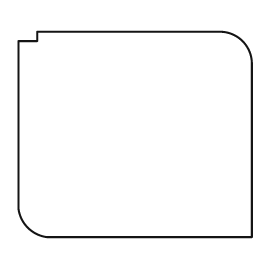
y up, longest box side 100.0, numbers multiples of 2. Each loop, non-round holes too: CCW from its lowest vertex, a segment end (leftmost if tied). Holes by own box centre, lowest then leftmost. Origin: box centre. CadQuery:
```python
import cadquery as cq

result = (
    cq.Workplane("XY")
    .moveTo(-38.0, -44.0)
    .lineTo(50.0, -44.0)
    .lineTo(50.0, 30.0)
    .threePointArc((46.0, 40.0), (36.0, 44.0))
    .lineTo(-42.0, 44.0)
    .lineTo(-42.0, 40.0)
    .lineTo(-50.0, 40.0)
    .lineTo(-50.0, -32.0)
    .threePointArc((-46.0, -40.0), (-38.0, -44.0))
    .close()
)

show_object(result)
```